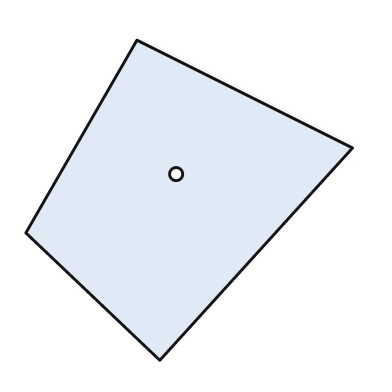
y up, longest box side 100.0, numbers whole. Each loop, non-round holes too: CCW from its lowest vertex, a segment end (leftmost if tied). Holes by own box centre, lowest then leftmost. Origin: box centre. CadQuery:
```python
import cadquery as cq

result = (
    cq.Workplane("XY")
    .moveTo(-9.0, -49.0)
    .lineTo(50.0, 16.0)
    .lineTo(-16.0, 49.0)
    .lineTo(-50.0, -10.0)
    .close()
    .moveTo(-4.0, 8.0)
    .circle(2.0)
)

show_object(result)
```